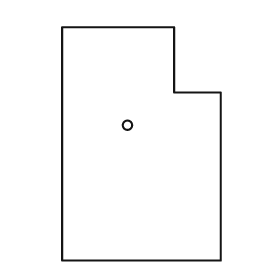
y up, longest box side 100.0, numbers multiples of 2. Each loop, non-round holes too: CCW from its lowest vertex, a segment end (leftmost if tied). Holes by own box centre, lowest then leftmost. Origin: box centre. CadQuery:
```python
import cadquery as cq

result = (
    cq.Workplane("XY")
    .moveTo(-34.0, -50.0)
    .lineTo(34.0, -50.0)
    .lineTo(34.0, 22.0)
    .lineTo(14.0, 22.0)
    .lineTo(14.0, 50.0)
    .lineTo(-34.0, 50.0)
    .close()
    .moveTo(-6.0, 8.0)
    .circle(2.0)
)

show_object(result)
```